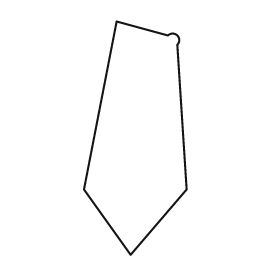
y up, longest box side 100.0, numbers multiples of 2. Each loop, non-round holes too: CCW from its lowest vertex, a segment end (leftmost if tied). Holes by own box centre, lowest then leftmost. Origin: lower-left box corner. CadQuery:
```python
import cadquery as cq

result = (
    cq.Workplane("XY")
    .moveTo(20.0, 0.0)
    .lineTo(44.0, 28.0)
    .lineTo(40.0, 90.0)
    .threePointArc((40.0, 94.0), (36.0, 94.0))
    .lineTo(14.0, 100.0)
    .lineTo(0.0, 28.0)
    .close()
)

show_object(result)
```